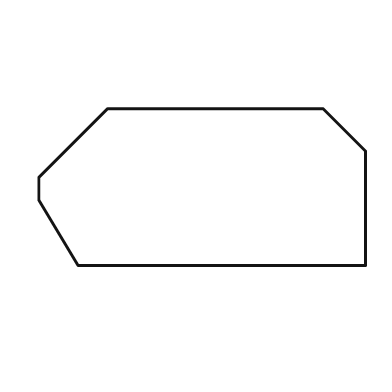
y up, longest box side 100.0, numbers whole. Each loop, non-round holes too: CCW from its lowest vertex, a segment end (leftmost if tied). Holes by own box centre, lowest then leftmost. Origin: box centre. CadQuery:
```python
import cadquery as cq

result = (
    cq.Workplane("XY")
    .moveTo(-38.0, -24.0)
    .lineTo(50.0, -24.0)
    .lineTo(50.0, 11.0)
    .lineTo(37.0, 24.0)
    .lineTo(-29.0, 24.0)
    .lineTo(-50.0, 3.0)
    .lineTo(-50.0, -4.0)
    .close()
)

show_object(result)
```